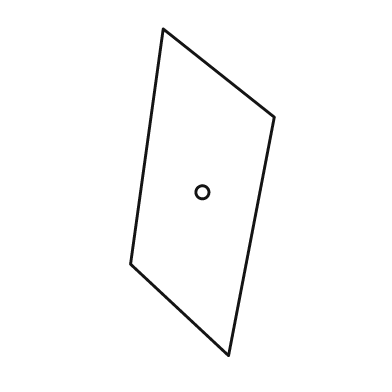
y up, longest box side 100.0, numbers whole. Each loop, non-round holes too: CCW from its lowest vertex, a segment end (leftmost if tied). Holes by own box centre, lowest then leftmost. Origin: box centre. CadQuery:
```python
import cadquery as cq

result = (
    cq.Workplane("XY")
    .moveTo(8.0, -50.0)
    .lineTo(22.0, 23.0)
    .lineTo(-12.0, 50.0)
    .lineTo(-22.0, -22.0)
    .close()
    .moveTo(0.0, 0.0)
    .circle(2.0)
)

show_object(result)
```